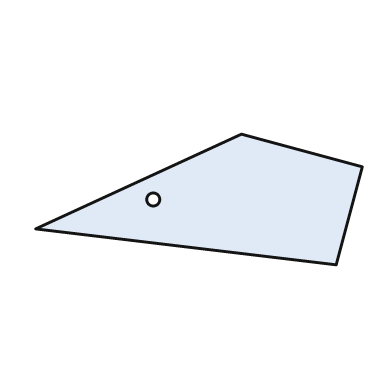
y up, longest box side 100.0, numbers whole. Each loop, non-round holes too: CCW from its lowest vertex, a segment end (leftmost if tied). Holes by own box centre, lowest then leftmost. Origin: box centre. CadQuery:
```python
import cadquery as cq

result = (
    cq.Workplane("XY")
    .moveTo(42.0, -20.0)
    .lineTo(50.0, 10.0)
    .lineTo(13.0, 20.0)
    .lineTo(-50.0, -9.0)
    .close()
    .moveTo(-14.0, 0.0)
    .circle(2.0)
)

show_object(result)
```